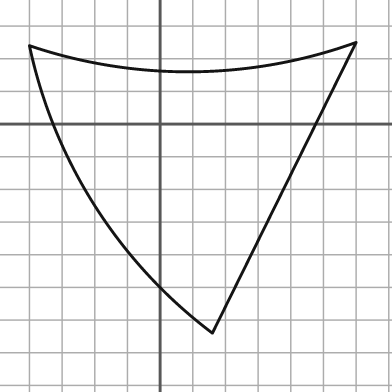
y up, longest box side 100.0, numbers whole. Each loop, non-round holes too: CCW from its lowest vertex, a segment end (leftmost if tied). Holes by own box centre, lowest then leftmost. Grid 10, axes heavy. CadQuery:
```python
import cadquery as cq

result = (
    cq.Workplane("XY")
    .moveTo(16.0, -64.0)
    .lineTo(60.0, 25.0)
    .threePointArc((10.0, 16.0), (-40.0, 24.0))
    .threePointArc((-20.0, -25.0), (16.0, -64.0))
    .close()
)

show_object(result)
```